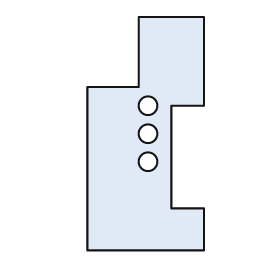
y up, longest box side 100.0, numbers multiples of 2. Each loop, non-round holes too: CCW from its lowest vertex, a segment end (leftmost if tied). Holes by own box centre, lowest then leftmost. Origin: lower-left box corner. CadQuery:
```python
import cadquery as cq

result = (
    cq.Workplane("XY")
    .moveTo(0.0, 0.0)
    .lineTo(50.0, 0.0)
    .lineTo(50.0, 18.0)
    .lineTo(36.0, 18.0)
    .lineTo(36.0, 62.0)
    .lineTo(50.0, 62.0)
    .lineTo(50.0, 100.0)
    .lineTo(22.0, 100.0)
    .lineTo(22.0, 70.0)
    .lineTo(0.0, 70.0)
    .close()
    .moveTo(26.0, 38.0)
    .circle(4.0)
    .moveTo(26.0, 50.0)
    .circle(4.0)
    .moveTo(26.0, 62.0)
    .circle(4.0)
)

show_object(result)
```